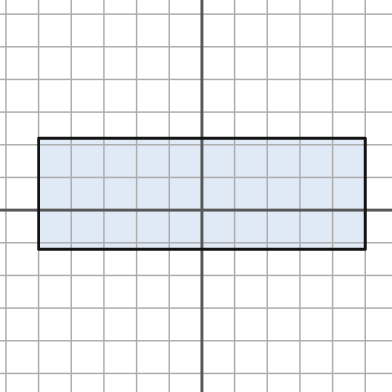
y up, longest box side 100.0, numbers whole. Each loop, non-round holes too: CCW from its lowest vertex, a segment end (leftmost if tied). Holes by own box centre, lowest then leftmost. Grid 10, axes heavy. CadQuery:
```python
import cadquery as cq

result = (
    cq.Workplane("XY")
    .moveTo(-50.0, -12.0)
    .lineTo(50.0, -12.0)
    .lineTo(50.0, 22.0)
    .lineTo(-50.0, 22.0)
    .close()
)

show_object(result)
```